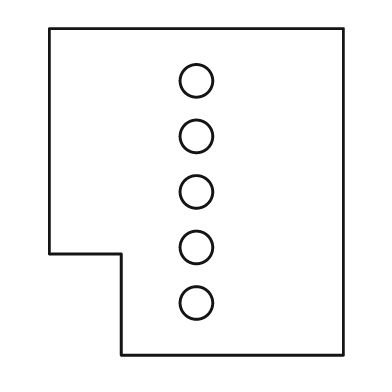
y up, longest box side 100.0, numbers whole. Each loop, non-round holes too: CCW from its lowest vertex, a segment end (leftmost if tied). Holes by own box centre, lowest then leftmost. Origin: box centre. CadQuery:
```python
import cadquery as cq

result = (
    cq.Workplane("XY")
    .moveTo(-23.0, -50.0)
    .lineTo(45.0, -50.0)
    .lineTo(45.0, 50.0)
    .lineTo(-45.0, 50.0)
    .lineTo(-45.0, -19.0)
    .lineTo(-23.0, -19.0)
    .close()
    .moveTo(0.0, -34.0)
    .circle(5.0)
    .moveTo(0.0, -17.0)
    .circle(5.0)
    .moveTo(0.0, 0.0)
    .circle(5.0)
    .moveTo(0.0, 17.0)
    .circle(5.0)
    .moveTo(0.0, 34.0)
    .circle(5.0)
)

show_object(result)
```